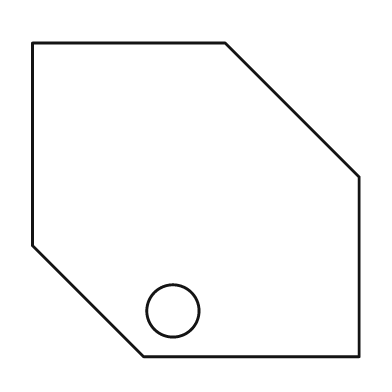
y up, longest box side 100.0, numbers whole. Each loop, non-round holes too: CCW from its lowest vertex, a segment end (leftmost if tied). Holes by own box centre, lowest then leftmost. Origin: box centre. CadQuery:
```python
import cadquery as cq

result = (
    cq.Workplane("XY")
    .moveTo(-16.0, -48.0)
    .lineTo(50.0, -48.0)
    .lineTo(50.0, 7.0)
    .lineTo(9.0, 48.0)
    .lineTo(-50.0, 48.0)
    .lineTo(-50.0, -14.0)
    .close()
    .moveTo(-7.0, -34.0)
    .circle(8.0)
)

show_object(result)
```